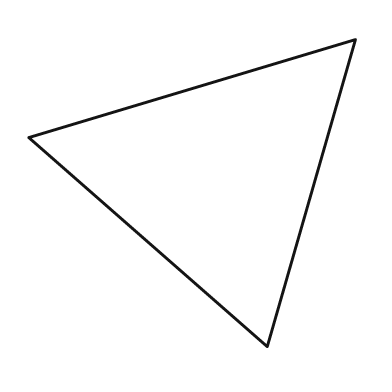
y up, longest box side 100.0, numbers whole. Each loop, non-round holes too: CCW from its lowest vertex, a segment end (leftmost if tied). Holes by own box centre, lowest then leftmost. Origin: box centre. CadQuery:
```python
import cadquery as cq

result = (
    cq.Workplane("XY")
    .moveTo(23.0, -47.0)
    .lineTo(50.0, 47.0)
    .lineTo(-50.0, 17.0)
    .close()
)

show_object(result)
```